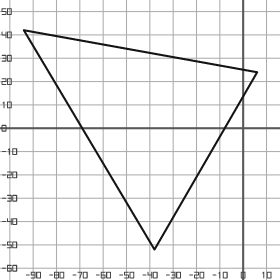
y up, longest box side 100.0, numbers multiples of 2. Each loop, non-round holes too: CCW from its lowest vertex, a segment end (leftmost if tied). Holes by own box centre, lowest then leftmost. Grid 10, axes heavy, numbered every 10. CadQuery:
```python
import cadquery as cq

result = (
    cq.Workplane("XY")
    .moveTo(-38.0, -52.0)
    .lineTo(6.0, 24.0)
    .lineTo(-94.0, 42.0)
    .close()
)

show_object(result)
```